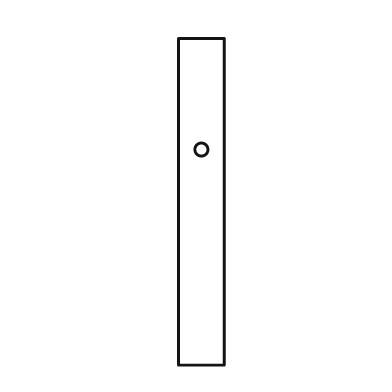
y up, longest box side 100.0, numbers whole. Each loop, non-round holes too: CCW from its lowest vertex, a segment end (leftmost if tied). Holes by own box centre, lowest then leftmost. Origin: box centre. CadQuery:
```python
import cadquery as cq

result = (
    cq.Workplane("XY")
    .moveTo(-7.0, -50.0)
    .lineTo(7.0, -50.0)
    .lineTo(7.0, 50.0)
    .lineTo(-7.0, 50.0)
    .close()
    .moveTo(0.0, 16.0)
    .circle(2.0)
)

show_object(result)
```